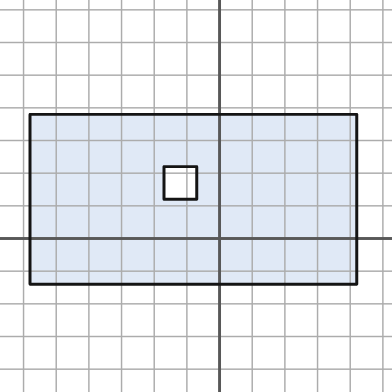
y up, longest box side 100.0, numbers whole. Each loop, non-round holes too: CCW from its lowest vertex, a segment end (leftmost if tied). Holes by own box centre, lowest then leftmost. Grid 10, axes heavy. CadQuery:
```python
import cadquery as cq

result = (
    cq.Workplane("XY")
    .moveTo(-58.0, -14.0)
    .lineTo(42.0, -14.0)
    .lineTo(42.0, 38.0)
    .lineTo(-58.0, 38.0)
    .close()
    .moveTo(-17.0, 12.0)
    .lineTo(-7.0, 12.0)
    .lineTo(-7.0, 22.0)
    .lineTo(-17.0, 22.0)
    .close()
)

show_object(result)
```